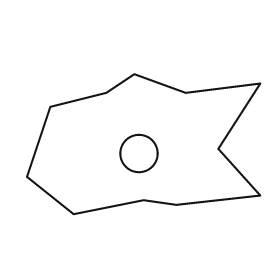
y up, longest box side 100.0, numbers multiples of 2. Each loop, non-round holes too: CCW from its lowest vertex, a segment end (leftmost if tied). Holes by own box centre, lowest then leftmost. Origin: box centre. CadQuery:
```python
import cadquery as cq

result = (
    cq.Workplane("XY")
    .moveTo(-30.0, -30.0)
    .lineTo(0.0, -24.0)
    .lineTo(14.0, -26.0)
    .lineTo(50.0, -22.0)
    .lineTo(32.0, -2.0)
    .lineTo(50.0, 26.0)
    .lineTo(18.0, 22.0)
    .lineTo(-4.0, 30.0)
    .lineTo(-16.0, 22.0)
    .lineTo(-40.0, 16.0)
    .lineTo(-50.0, -14.0)
    .close()
    .moveTo(-2.0, -4.0)
    .circle(8.0)
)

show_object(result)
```